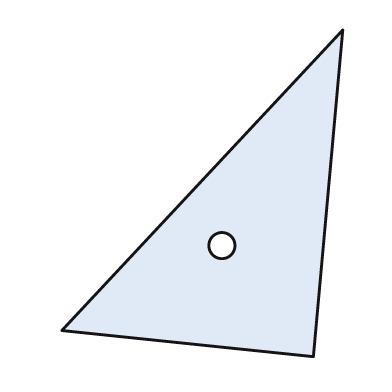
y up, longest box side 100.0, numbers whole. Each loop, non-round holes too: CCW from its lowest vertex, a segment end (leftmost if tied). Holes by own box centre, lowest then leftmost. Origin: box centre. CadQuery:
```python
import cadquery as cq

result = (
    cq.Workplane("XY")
    .moveTo(34.0, -50.0)
    .lineTo(43.0, 50.0)
    .lineTo(-43.0, -42.0)
    .close()
    .moveTo(6.0, -16.0)
    .circle(4.0)
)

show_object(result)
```